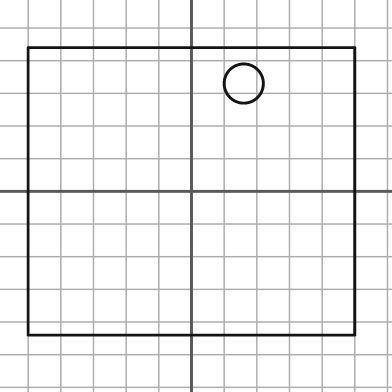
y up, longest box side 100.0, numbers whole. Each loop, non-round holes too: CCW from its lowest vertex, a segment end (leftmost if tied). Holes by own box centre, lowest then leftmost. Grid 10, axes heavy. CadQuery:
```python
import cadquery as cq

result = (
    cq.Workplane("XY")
    .moveTo(-50.0, -44.0)
    .lineTo(50.0, -44.0)
    .lineTo(50.0, 44.0)
    .lineTo(-50.0, 44.0)
    .close()
    .moveTo(16.0, 33.0)
    .circle(6.0)
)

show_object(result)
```